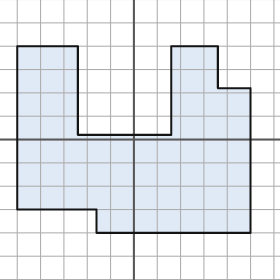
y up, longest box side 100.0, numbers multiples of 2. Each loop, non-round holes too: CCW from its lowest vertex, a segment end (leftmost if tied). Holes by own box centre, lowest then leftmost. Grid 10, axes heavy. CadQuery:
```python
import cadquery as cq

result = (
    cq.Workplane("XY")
    .moveTo(-16.0, -40.0)
    .lineTo(50.0, -40.0)
    .lineTo(50.0, 22.0)
    .lineTo(36.0, 22.0)
    .lineTo(36.0, 40.0)
    .lineTo(16.0, 40.0)
    .lineTo(16.0, 2.0)
    .lineTo(-24.0, 2.0)
    .lineTo(-24.0, 40.0)
    .lineTo(-50.0, 40.0)
    .lineTo(-50.0, -30.0)
    .lineTo(-16.0, -30.0)
    .close()
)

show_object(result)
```